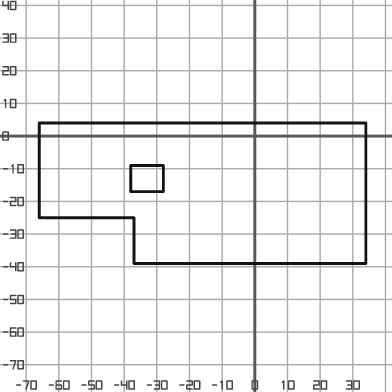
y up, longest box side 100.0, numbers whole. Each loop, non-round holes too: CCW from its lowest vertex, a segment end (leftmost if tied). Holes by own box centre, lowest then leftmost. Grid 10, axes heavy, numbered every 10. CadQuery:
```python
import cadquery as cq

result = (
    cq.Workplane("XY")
    .moveTo(-37.0, -39.0)
    .lineTo(34.0, -39.0)
    .lineTo(34.0, 4.0)
    .lineTo(-66.0, 4.0)
    .lineTo(-66.0, -25.0)
    .lineTo(-37.0, -25.0)
    .close()
    .moveTo(-38.0, -17.0)
    .lineTo(-28.0, -17.0)
    .lineTo(-28.0, -9.0)
    .lineTo(-38.0, -9.0)
    .close()
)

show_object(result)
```